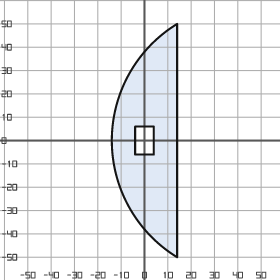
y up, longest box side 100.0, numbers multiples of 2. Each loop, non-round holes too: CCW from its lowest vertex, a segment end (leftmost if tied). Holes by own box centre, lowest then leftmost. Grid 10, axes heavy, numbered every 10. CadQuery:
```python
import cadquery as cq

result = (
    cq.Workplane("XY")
    .moveTo(14.0, -50.0)
    .lineTo(14.0, 50.0)
    .threePointArc((-14.0, 0.0), (14.0, -50.0))
    .close()
    .moveTo(-4.0, -6.0)
    .lineTo(4.0, -6.0)
    .lineTo(4.0, 6.0)
    .lineTo(-4.0, 6.0)
    .close()
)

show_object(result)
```